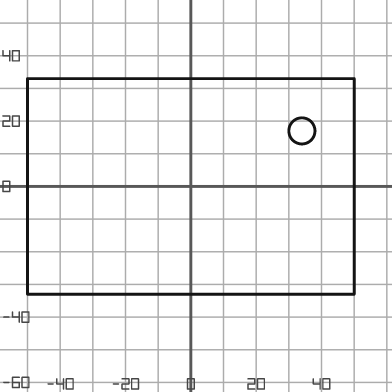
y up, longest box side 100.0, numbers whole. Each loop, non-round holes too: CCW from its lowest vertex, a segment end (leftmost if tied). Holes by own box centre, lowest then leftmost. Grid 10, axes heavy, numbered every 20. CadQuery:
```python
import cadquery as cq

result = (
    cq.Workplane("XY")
    .moveTo(-50.0, -33.0)
    .lineTo(50.0, -33.0)
    .lineTo(50.0, 33.0)
    .lineTo(-50.0, 33.0)
    .close()
    .moveTo(34.0, 17.0)
    .circle(4.0)
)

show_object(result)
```